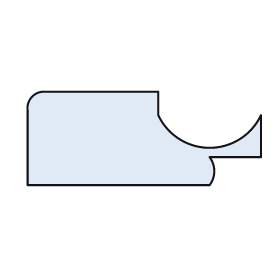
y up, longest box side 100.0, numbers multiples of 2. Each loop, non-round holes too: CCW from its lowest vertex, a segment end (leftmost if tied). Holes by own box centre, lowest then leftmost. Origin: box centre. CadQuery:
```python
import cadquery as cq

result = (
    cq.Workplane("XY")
    .moveTo(-50.0, -20.0)
    .lineTo(28.0, -20.0)
    .threePointArc((30.0, -14.0), (28.0, -8.0))
    .lineTo(50.0, -8.0)
    .lineTo(50.0, 10.0)
    .threePointArc((28.0, -4.0), (6.0, 10.0))
    .lineTo(6.0, 20.0)
    .lineTo(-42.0, 20.0)
    .threePointArc((-48.0, 18.0), (-50.0, 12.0))
    .close()
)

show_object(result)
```